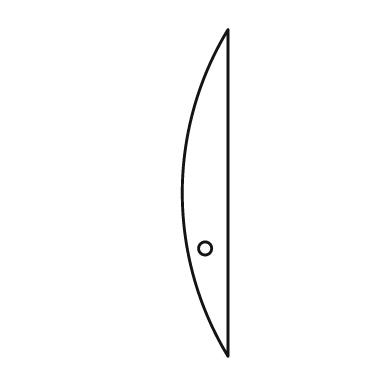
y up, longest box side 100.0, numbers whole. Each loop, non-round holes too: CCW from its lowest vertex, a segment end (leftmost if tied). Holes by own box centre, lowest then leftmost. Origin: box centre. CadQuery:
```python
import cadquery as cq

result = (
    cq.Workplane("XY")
    .moveTo(7.0, -50.0)
    .lineTo(7.0, 50.0)
    .threePointArc((-7.0, 0.0), (7.0, -50.0))
    .close()
    .moveTo(0.0, -17.0)
    .circle(2.0)
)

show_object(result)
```